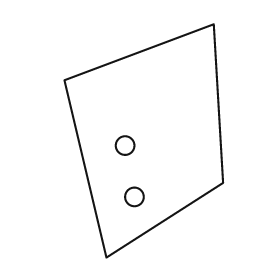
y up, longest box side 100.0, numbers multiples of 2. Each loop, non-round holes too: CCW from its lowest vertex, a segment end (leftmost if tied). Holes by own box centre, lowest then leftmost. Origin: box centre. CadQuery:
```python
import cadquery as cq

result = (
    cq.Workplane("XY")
    .moveTo(-16.0, -50.0)
    .lineTo(34.0, -18.0)
    .lineTo(30.0, 50.0)
    .lineTo(-34.0, 26.0)
    .close()
    .moveTo(-4.0, -24.0)
    .circle(4.0)
    .moveTo(-8.0, -2.0)
    .circle(4.0)
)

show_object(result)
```